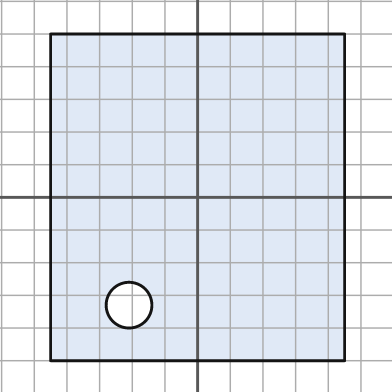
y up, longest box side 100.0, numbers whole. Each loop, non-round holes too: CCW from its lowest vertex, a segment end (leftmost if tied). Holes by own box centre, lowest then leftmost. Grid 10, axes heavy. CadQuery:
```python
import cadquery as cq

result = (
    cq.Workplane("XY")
    .moveTo(-45.0, -50.0)
    .lineTo(45.0, -50.0)
    .lineTo(45.0, 50.0)
    .lineTo(-45.0, 50.0)
    .close()
    .moveTo(-21.0, -33.0)
    .circle(7.0)
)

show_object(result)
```